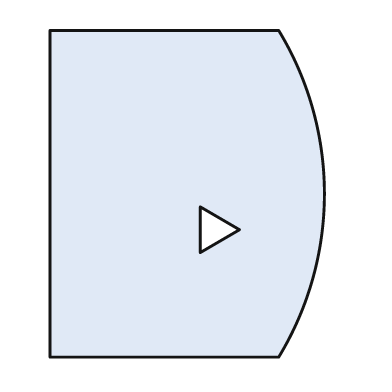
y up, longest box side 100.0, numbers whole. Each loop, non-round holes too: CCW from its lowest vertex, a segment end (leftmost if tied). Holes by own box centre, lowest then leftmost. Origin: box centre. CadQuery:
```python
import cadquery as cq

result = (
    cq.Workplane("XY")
    .moveTo(-42.0, -50.0)
    .lineTo(28.0, -50.0)
    .threePointArc((42.0, 0.0), (28.0, 50.0))
    .lineTo(-42.0, 50.0)
    .close()
    .moveTo(4.0, -18.0)
    .lineTo(16.0, -11.0)
    .lineTo(4.0, -4.0)
    .close()
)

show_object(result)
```